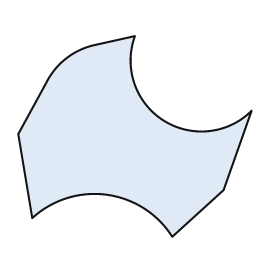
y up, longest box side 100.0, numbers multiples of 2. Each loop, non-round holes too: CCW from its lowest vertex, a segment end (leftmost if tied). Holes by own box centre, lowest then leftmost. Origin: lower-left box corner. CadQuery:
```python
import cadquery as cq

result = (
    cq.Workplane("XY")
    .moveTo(66.0, 0.0)
    .lineTo(88.0, 20.0)
    .lineTo(100.0, 54.0)
    .threePointArc((62.0, 50.0), (50.0, 86.0))
    .lineTo(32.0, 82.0)
    .threePointArc((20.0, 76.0), (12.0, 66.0))
    .lineTo(0.0, 44.0)
    .lineTo(6.0, 8.0)
    .threePointArc((38.0, 18.0), (66.0, 0.0))
    .close()
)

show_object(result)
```